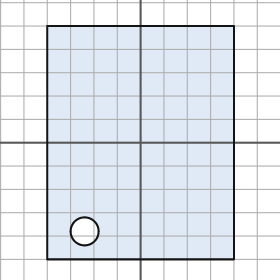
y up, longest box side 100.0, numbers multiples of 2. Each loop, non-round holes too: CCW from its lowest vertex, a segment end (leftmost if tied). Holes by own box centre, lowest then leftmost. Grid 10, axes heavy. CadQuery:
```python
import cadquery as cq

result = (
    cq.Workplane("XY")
    .moveTo(-40.0, -50.0)
    .lineTo(40.0, -50.0)
    .lineTo(40.0, 50.0)
    .lineTo(-40.0, 50.0)
    .close()
    .moveTo(-24.0, -38.0)
    .circle(6.0)
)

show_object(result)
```